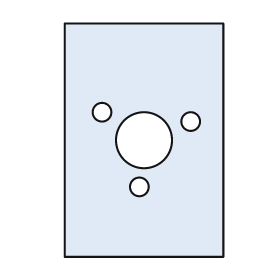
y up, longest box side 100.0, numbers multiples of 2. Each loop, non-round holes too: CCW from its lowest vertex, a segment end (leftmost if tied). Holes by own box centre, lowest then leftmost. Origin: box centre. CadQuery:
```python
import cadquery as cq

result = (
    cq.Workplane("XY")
    .moveTo(-34.0, -50.0)
    .lineTo(34.0, -50.0)
    .lineTo(34.0, 50.0)
    .lineTo(-34.0, 50.0)
    .close()
    .moveTo(-2.0, -20.0)
    .circle(4.0)
    .moveTo(0.0, 0.0)
    .circle(12.0)
    .moveTo(20.0, 8.0)
    .circle(4.0)
    .moveTo(-18.0, 12.0)
    .circle(4.0)
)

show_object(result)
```